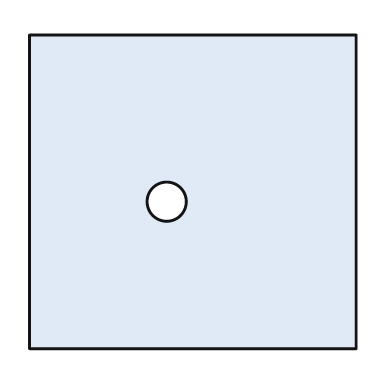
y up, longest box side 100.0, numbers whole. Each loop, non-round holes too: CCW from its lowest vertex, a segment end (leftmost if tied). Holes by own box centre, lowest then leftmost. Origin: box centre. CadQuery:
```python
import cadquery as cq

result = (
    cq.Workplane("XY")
    .moveTo(-50.0, -48.0)
    .lineTo(50.0, -48.0)
    .lineTo(50.0, 48.0)
    .lineTo(-50.0, 48.0)
    .close()
    .moveTo(-8.0, -3.0)
    .circle(6.0)
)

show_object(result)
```